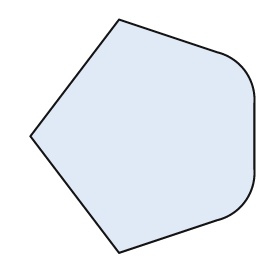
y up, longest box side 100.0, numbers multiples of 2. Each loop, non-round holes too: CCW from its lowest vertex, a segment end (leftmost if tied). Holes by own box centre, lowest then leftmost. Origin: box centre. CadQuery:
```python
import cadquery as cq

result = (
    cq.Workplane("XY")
    .moveTo(-10.0, -50.0)
    .lineTo(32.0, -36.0)
    .threePointArc((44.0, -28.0), (48.0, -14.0))
    .lineTo(48.0, 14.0)
    .threePointArc((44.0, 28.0), (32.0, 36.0))
    .lineTo(-10.0, 50.0)
    .lineTo(-48.0, 0.0)
    .close()
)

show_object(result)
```